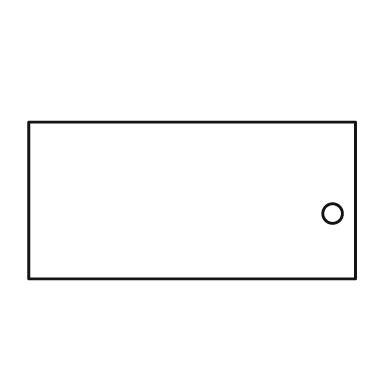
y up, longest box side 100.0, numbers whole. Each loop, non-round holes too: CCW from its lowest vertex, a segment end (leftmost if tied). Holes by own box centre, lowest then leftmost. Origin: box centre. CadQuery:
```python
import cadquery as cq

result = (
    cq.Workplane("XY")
    .moveTo(-50.0, -24.0)
    .lineTo(50.0, -24.0)
    .lineTo(50.0, 24.0)
    .lineTo(-50.0, 24.0)
    .close()
    .moveTo(43.0, -4.0)
    .circle(3.0)
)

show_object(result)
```